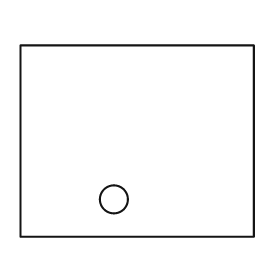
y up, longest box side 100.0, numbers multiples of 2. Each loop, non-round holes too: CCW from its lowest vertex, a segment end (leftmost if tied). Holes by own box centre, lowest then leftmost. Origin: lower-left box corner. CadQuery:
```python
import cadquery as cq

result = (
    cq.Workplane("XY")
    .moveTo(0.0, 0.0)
    .lineTo(100.0, 0.0)
    .lineTo(100.0, 82.0)
    .lineTo(0.0, 82.0)
    .close()
    .moveTo(40.0, 16.0)
    .circle(6.0)
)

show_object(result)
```